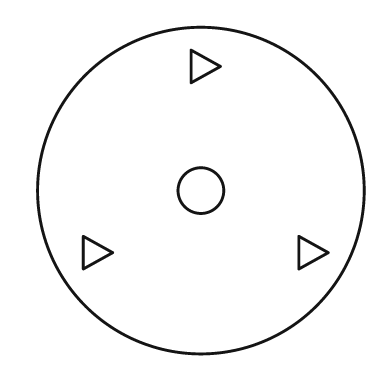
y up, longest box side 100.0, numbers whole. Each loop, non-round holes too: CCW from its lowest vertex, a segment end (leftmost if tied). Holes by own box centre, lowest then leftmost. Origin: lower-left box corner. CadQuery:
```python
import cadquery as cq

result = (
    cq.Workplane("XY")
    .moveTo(50.0, 50.0)
    .circle(50.0)
    .moveTo(14.0, 26.0)
    .lineTo(23.0, 31.0)
    .lineTo(14.0, 36.0)
    .close()
    .moveTo(80.0, 26.0)
    .lineTo(89.0, 31.0)
    .lineTo(80.0, 36.0)
    .close()
    .moveTo(50.0, 50.0)
    .circle(7.0)
    .moveTo(47.0, 83.0)
    .lineTo(56.0, 88.0)
    .lineTo(47.0, 93.0)
    .close()
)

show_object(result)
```